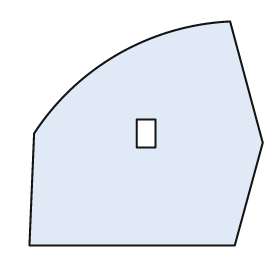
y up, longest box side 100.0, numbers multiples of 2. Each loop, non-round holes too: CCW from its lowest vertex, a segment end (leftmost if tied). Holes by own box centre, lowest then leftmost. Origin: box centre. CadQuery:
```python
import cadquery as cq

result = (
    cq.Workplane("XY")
    .moveTo(-50.0, -48.0)
    .lineTo(38.0, -48.0)
    .lineTo(50.0, -4.0)
    .lineTo(36.0, 48.0)
    .threePointArc((-12.0, 34.0), (-48.0, 0.0))
    .close()
    .moveTo(-4.0, -6.0)
    .lineTo(4.0, -6.0)
    .lineTo(4.0, 6.0)
    .lineTo(-4.0, 6.0)
    .close()
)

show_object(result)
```